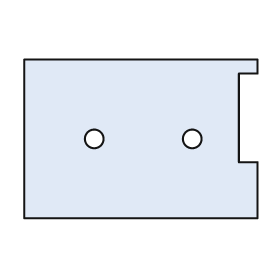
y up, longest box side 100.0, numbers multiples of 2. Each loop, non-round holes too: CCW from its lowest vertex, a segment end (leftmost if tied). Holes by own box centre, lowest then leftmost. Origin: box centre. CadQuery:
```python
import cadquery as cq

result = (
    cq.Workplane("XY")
    .moveTo(-50.0, -34.0)
    .lineTo(50.0, -34.0)
    .lineTo(50.0, -10.0)
    .lineTo(42.0, -10.0)
    .lineTo(42.0, 28.0)
    .lineTo(50.0, 28.0)
    .lineTo(50.0, 34.0)
    .lineTo(-50.0, 34.0)
    .close()
    .moveTo(-20.0, 0.0)
    .circle(4.0)
    .moveTo(22.0, 0.0)
    .circle(4.0)
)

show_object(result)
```